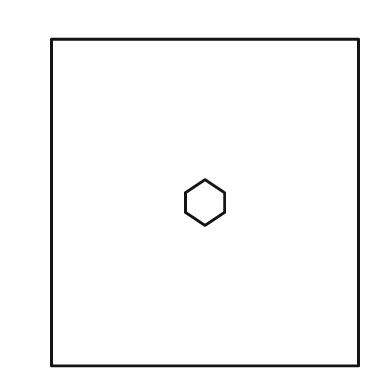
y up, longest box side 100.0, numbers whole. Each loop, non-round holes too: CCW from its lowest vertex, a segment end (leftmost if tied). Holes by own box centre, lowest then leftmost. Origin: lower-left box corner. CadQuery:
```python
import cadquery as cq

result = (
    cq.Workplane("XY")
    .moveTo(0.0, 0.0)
    .lineTo(94.0, 0.0)
    .lineTo(94.0, 100.0)
    .lineTo(0.0, 100.0)
    .close()
    .moveTo(47.0, 43.0)
    .lineTo(53.0, 47.0)
    .lineTo(53.0, 53.0)
    .lineTo(47.0, 57.0)
    .lineTo(41.0, 53.0)
    .lineTo(41.0, 47.0)
    .close()
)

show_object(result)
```